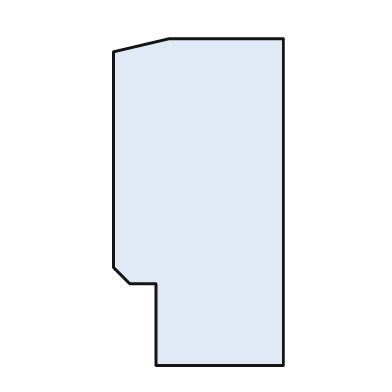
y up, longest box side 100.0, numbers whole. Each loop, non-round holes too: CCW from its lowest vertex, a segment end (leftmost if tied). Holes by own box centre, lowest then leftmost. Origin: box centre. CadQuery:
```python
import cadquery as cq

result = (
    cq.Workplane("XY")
    .moveTo(-13.0, -50.0)
    .lineTo(26.0, -50.0)
    .lineTo(26.0, 50.0)
    .lineTo(-9.0, 50.0)
    .lineTo(-26.0, 46.0)
    .lineTo(-26.0, -20.0)
    .lineTo(-21.0, -25.0)
    .lineTo(-13.0, -25.0)
    .close()
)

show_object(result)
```